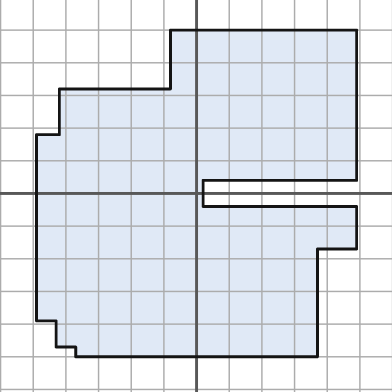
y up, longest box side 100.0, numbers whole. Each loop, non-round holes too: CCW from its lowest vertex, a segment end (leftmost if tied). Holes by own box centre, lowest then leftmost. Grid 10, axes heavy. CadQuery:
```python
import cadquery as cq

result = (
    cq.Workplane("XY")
    .moveTo(-37.0, -50.0)
    .lineTo(37.0, -50.0)
    .lineTo(37.0, -17.0)
    .lineTo(49.0, -17.0)
    .lineTo(49.0, -4.0)
    .lineTo(2.0, -4.0)
    .lineTo(2.0, 4.0)
    .lineTo(49.0, 4.0)
    .lineTo(49.0, 50.0)
    .lineTo(-8.0, 50.0)
    .lineTo(-8.0, 32.0)
    .lineTo(-42.0, 32.0)
    .lineTo(-42.0, 18.0)
    .lineTo(-49.0, 18.0)
    .lineTo(-49.0, -39.0)
    .lineTo(-43.0, -39.0)
    .lineTo(-43.0, -47.0)
    .lineTo(-37.0, -47.0)
    .close()
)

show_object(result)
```